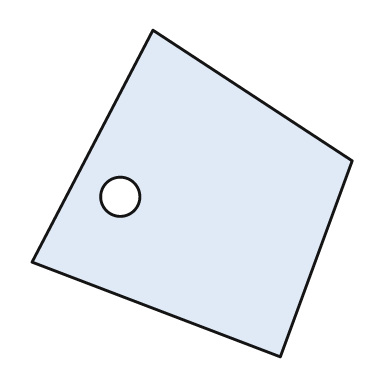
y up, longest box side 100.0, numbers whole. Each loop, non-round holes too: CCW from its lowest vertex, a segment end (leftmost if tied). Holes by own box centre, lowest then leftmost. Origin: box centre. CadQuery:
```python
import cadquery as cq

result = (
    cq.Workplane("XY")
    .moveTo(27.0, -50.0)
    .lineTo(49.0, 10.0)
    .lineTo(-12.0, 50.0)
    .lineTo(-49.0, -21.0)
    .close()
    .moveTo(-22.0, -1.0)
    .circle(6.0)
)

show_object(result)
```